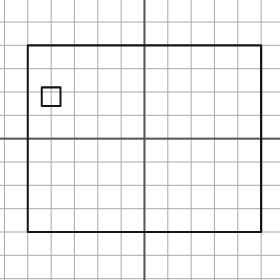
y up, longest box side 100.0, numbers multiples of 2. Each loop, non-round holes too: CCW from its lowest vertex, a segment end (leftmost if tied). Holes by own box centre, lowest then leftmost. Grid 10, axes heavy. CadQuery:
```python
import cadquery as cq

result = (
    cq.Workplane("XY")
    .moveTo(-50.0, -40.0)
    .lineTo(50.0, -40.0)
    .lineTo(50.0, 40.0)
    .lineTo(-50.0, 40.0)
    .close()
    .moveTo(-44.0, 14.0)
    .lineTo(-36.0, 14.0)
    .lineTo(-36.0, 22.0)
    .lineTo(-44.0, 22.0)
    .close()
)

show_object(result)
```